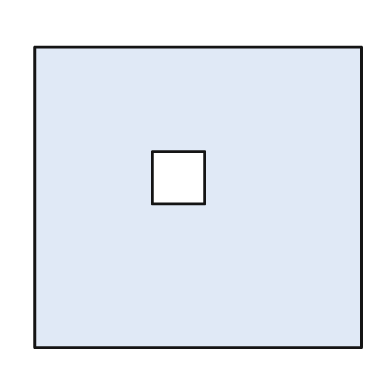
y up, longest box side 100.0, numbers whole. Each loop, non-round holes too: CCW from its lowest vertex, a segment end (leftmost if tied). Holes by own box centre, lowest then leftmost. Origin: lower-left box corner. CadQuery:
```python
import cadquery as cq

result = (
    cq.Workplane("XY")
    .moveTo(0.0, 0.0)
    .lineTo(100.0, 0.0)
    .lineTo(100.0, 92.0)
    .lineTo(0.0, 92.0)
    .close()
    .moveTo(36.0, 44.0)
    .lineTo(52.0, 44.0)
    .lineTo(52.0, 60.0)
    .lineTo(36.0, 60.0)
    .close()
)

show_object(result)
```